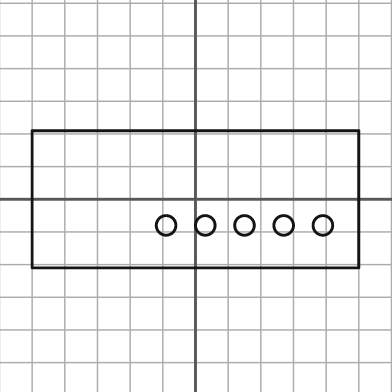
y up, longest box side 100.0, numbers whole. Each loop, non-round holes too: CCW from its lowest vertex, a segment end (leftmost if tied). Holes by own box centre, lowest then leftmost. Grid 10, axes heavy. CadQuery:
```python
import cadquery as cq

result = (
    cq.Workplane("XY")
    .moveTo(-50.0, -21.0)
    .lineTo(50.0, -21.0)
    .lineTo(50.0, 21.0)
    .lineTo(-50.0, 21.0)
    .close()
    .moveTo(-9.0, -8.0)
    .circle(3.0)
    .moveTo(3.0, -8.0)
    .circle(3.0)
    .moveTo(15.0, -8.0)
    .circle(3.0)
    .moveTo(27.0, -8.0)
    .circle(3.0)
    .moveTo(39.0, -8.0)
    .circle(3.0)
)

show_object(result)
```